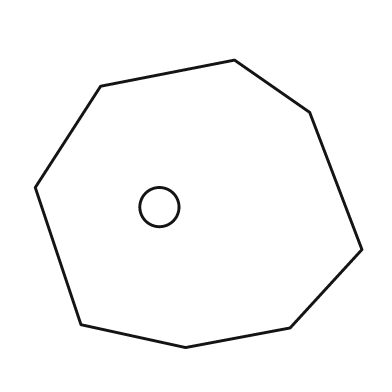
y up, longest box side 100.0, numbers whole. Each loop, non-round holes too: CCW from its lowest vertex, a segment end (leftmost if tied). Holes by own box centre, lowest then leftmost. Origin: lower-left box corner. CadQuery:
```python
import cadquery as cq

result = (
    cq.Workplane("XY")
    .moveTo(46.0, 0.0)
    .lineTo(78.0, 6.0)
    .lineTo(100.0, 30.0)
    .lineTo(84.0, 72.0)
    .lineTo(61.0, 88.0)
    .lineTo(20.0, 80.0)
    .lineTo(0.0, 49.0)
    .lineTo(14.0, 7.0)
    .close()
    .moveTo(38.0, 43.0)
    .circle(6.0)
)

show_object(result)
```